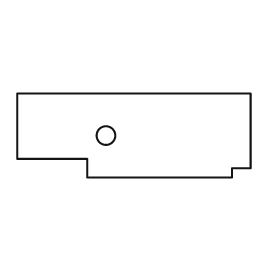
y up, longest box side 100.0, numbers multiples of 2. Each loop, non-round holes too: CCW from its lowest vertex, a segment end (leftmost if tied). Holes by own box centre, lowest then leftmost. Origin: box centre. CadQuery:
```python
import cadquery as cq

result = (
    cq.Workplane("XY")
    .moveTo(-20.0, -18.0)
    .lineTo(42.0, -18.0)
    .lineTo(42.0, -14.0)
    .lineTo(50.0, -14.0)
    .lineTo(50.0, 18.0)
    .lineTo(-50.0, 18.0)
    .lineTo(-50.0, -10.0)
    .lineTo(-20.0, -10.0)
    .close()
    .moveTo(-12.0, 0.0)
    .circle(4.0)
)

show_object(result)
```